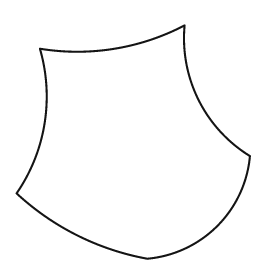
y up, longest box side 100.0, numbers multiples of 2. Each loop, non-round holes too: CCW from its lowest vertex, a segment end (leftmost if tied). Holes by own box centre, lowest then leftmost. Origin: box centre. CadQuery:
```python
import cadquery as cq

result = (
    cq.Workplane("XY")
    .moveTo(6.0, -50.0)
    .threePointArc((36.0, -36.0), (50.0, -6.0))
    .threePointArc((28.0, 18.0), (22.0, 50.0))
    .threePointArc((-8.0, 40.0), (-40.0, 40.0))
    .threePointArc((-38.0, 8.0), (-50.0, -22.0))
    .threePointArc((-24.0, -40.0), (6.0, -50.0))
    .close()
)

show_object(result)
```